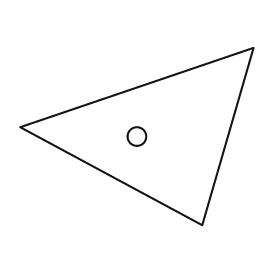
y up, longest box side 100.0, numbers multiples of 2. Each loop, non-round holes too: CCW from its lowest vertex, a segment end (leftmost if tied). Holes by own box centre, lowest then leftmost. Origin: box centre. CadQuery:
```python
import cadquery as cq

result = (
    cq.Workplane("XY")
    .moveTo(28.0, -38.0)
    .lineTo(50.0, 38.0)
    .lineTo(-50.0, 4.0)
    .close()
    .moveTo(0.0, 0.0)
    .circle(4.0)
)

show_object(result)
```